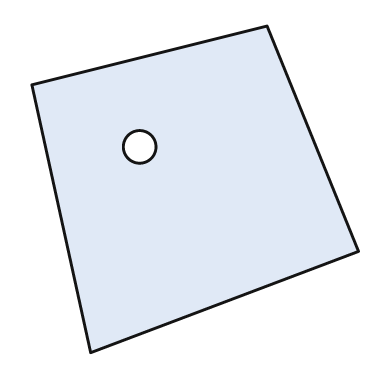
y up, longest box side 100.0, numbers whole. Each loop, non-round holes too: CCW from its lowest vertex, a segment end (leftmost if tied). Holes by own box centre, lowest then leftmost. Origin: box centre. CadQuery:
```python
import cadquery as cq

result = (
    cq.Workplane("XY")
    .moveTo(-32.0, -50.0)
    .lineTo(50.0, -19.0)
    .lineTo(22.0, 50.0)
    .lineTo(-50.0, 32.0)
    .close()
    .moveTo(-17.0, 13.0)
    .circle(5.0)
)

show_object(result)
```